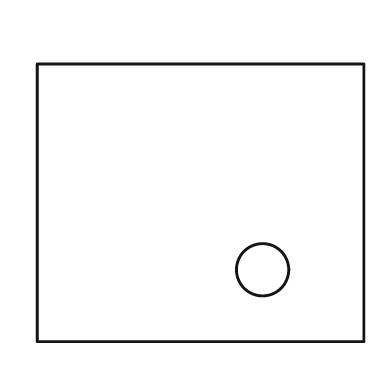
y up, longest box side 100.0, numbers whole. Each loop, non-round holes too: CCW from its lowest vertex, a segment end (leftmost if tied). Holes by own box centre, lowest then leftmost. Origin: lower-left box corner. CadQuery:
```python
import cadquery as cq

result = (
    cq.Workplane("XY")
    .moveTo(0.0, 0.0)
    .lineTo(100.0, 0.0)
    .lineTo(100.0, 85.0)
    .lineTo(0.0, 85.0)
    .close()
    .moveTo(69.0, 22.0)
    .circle(8.0)
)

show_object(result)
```